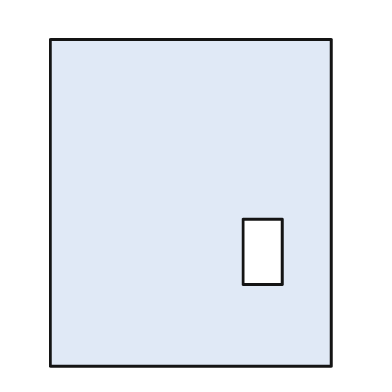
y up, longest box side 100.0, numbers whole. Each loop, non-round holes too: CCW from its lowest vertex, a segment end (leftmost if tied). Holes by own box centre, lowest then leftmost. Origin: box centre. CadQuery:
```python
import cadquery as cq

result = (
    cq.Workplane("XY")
    .moveTo(-43.0, -50.0)
    .lineTo(43.0, -50.0)
    .lineTo(43.0, 50.0)
    .lineTo(-43.0, 50.0)
    .close()
    .moveTo(16.0, -25.0)
    .lineTo(28.0, -25.0)
    .lineTo(28.0, -5.0)
    .lineTo(16.0, -5.0)
    .close()
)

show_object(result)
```